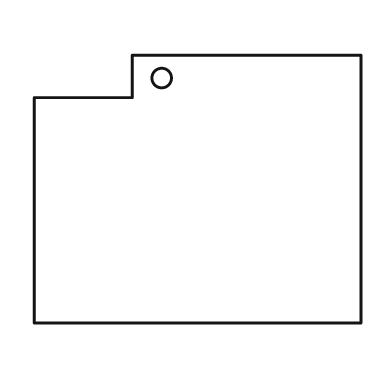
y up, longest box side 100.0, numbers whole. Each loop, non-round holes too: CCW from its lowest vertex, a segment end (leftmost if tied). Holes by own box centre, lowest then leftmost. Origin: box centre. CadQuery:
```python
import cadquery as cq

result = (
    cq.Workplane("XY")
    .moveTo(-50.0, -41.0)
    .lineTo(50.0, -41.0)
    .lineTo(50.0, 41.0)
    .lineTo(-20.0, 41.0)
    .lineTo(-20.0, 28.0)
    .lineTo(-50.0, 28.0)
    .close()
    .moveTo(-11.0, 34.0)
    .circle(3.0)
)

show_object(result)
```